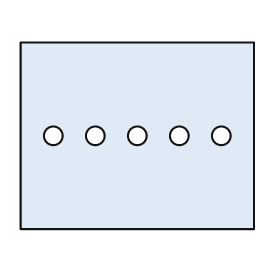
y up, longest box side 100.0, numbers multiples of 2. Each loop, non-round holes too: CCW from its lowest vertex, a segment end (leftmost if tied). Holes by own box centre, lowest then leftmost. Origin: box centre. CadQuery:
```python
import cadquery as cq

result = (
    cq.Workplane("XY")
    .moveTo(-50.0, -40.0)
    .lineTo(50.0, -40.0)
    .lineTo(50.0, 40.0)
    .lineTo(-50.0, 40.0)
    .close()
    .moveTo(-36.0, 0.0)
    .circle(4.0)
    .moveTo(-18.0, 0.0)
    .circle(4.0)
    .moveTo(0.0, 0.0)
    .circle(4.0)
    .moveTo(18.0, 0.0)
    .circle(4.0)
    .moveTo(36.0, 0.0)
    .circle(4.0)
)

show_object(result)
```